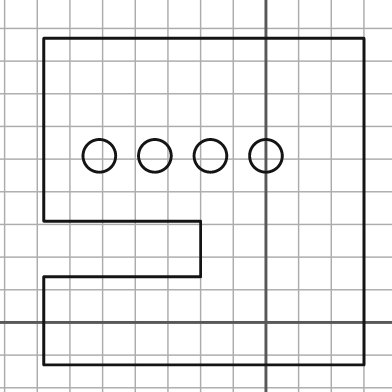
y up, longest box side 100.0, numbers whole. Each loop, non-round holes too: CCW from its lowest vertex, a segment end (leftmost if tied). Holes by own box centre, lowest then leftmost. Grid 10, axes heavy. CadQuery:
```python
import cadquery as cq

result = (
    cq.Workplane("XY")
    .moveTo(-68.0, -13.0)
    .lineTo(30.0, -13.0)
    .lineTo(30.0, 87.0)
    .lineTo(-68.0, 87.0)
    .lineTo(-68.0, 31.0)
    .lineTo(-20.0, 31.0)
    .lineTo(-20.0, 14.0)
    .lineTo(-68.0, 14.0)
    .close()
    .moveTo(-51.0, 51.0)
    .circle(5.0)
    .moveTo(-34.0, 51.0)
    .circle(5.0)
    .moveTo(-17.0, 51.0)
    .circle(5.0)
    .moveTo(0.0, 51.0)
    .circle(5.0)
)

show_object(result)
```